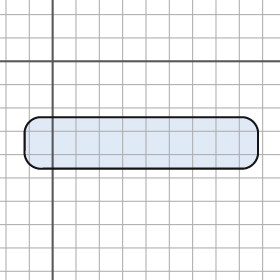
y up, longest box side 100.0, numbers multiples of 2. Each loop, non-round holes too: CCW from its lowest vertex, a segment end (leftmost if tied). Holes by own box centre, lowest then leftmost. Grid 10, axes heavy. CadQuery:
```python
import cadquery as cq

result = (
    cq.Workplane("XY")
    .moveTo(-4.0, -46.0)
    .lineTo(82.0, -46.0)
    .threePointArc((86.0, -44.0), (88.0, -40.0))
    .lineTo(88.0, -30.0)
    .threePointArc((86.0, -26.0), (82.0, -24.0))
    .lineTo(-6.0, -24.0)
    .threePointArc((-10.0, -26.0), (-12.0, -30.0))
    .lineTo(-12.0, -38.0)
    .threePointArc((-10.0, -44.0), (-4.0, -46.0))
    .close()
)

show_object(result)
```